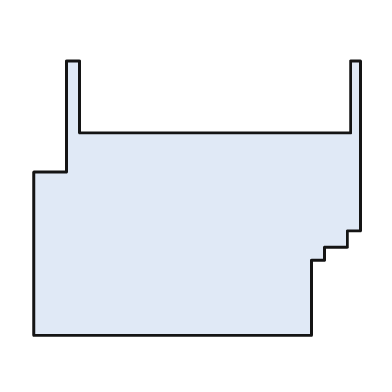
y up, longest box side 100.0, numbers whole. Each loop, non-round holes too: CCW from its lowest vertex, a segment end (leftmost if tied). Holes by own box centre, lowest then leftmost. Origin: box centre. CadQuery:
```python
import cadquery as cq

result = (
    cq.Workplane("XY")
    .moveTo(-50.0, -42.0)
    .lineTo(35.0, -42.0)
    .lineTo(35.0, -19.0)
    .lineTo(39.0, -19.0)
    .lineTo(39.0, -15.0)
    .lineTo(46.0, -15.0)
    .lineTo(46.0, -10.0)
    .lineTo(50.0, -10.0)
    .lineTo(50.0, 42.0)
    .lineTo(47.0, 42.0)
    .lineTo(47.0, 20.0)
    .lineTo(-36.0, 20.0)
    .lineTo(-36.0, 42.0)
    .lineTo(-40.0, 42.0)
    .lineTo(-40.0, 8.0)
    .lineTo(-50.0, 8.0)
    .close()
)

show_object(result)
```